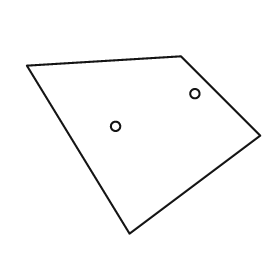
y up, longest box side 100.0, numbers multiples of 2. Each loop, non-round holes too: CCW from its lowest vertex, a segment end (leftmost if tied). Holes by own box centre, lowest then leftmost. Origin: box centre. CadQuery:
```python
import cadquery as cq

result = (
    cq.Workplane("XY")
    .moveTo(-6.0, -38.0)
    .lineTo(50.0, 4.0)
    .lineTo(16.0, 38.0)
    .lineTo(-50.0, 34.0)
    .close()
    .moveTo(-12.0, 8.0)
    .circle(2.0)
    .moveTo(22.0, 22.0)
    .circle(2.0)
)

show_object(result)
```